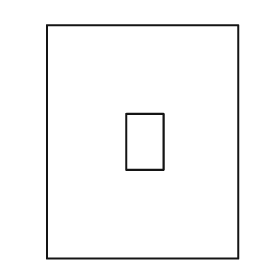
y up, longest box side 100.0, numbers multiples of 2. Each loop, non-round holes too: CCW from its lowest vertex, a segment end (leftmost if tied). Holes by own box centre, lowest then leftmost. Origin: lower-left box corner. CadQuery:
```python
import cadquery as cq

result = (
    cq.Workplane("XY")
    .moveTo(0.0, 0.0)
    .lineTo(82.0, 0.0)
    .lineTo(82.0, 100.0)
    .lineTo(0.0, 100.0)
    .close()
    .moveTo(34.0, 38.0)
    .lineTo(50.0, 38.0)
    .lineTo(50.0, 62.0)
    .lineTo(34.0, 62.0)
    .close()
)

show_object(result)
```